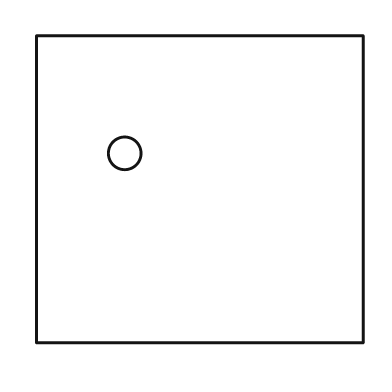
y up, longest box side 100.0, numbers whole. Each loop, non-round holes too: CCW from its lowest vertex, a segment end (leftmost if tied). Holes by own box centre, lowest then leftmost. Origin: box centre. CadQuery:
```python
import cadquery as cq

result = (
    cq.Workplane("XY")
    .moveTo(-50.0, -47.0)
    .lineTo(50.0, -47.0)
    .lineTo(50.0, 47.0)
    .lineTo(-50.0, 47.0)
    .close()
    .moveTo(-23.0, 11.0)
    .circle(5.0)
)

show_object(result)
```